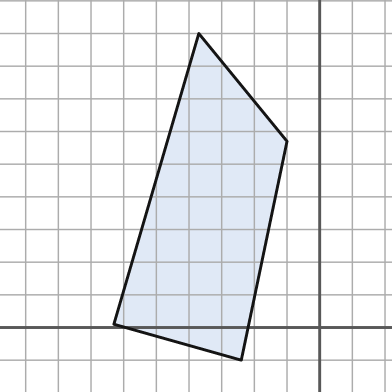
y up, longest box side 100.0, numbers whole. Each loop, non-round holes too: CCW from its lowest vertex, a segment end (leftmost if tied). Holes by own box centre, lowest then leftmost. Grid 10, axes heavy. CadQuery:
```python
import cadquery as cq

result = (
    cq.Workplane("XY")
    .moveTo(-24.0, -10.0)
    .lineTo(-10.0, 57.0)
    .lineTo(-37.0, 90.0)
    .lineTo(-63.0, 1.0)
    .close()
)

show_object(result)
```